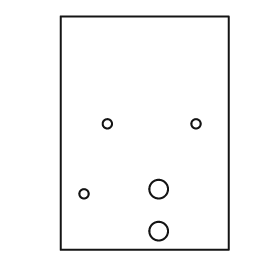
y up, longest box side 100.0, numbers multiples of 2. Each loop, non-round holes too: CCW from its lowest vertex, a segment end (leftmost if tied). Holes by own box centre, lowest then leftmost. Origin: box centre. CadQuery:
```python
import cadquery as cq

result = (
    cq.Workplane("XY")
    .moveTo(-36.0, -50.0)
    .lineTo(36.0, -50.0)
    .lineTo(36.0, 50.0)
    .lineTo(-36.0, 50.0)
    .close()
    .moveTo(6.0, -42.0)
    .circle(4.0)
    .moveTo(-26.0, -26.0)
    .circle(2.0)
    .moveTo(6.0, -24.0)
    .circle(4.0)
    .moveTo(-16.0, 4.0)
    .circle(2.0)
    .moveTo(22.0, 4.0)
    .circle(2.0)
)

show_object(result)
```